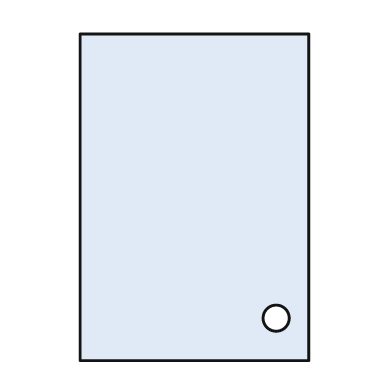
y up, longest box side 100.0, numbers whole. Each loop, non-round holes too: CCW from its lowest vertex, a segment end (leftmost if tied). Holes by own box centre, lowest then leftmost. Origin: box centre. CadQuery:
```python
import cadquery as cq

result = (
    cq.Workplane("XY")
    .moveTo(-35.0, -50.0)
    .lineTo(35.0, -50.0)
    .lineTo(35.0, 50.0)
    .lineTo(-35.0, 50.0)
    .close()
    .moveTo(25.0, -37.0)
    .circle(4.0)
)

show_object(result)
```